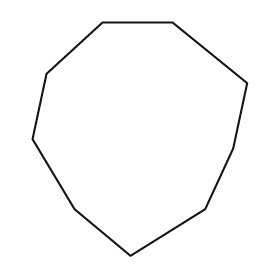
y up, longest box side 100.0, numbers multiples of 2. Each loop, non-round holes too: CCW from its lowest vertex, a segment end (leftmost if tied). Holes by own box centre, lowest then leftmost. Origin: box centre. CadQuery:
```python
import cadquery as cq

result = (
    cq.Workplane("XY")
    .moveTo(-4.0, -50.0)
    .lineTo(28.0, -30.0)
    .lineTo(40.0, -4.0)
    .lineTo(46.0, 24.0)
    .lineTo(14.0, 50.0)
    .lineTo(-16.0, 50.0)
    .lineTo(-40.0, 28.0)
    .lineTo(-46.0, 0.0)
    .lineTo(-28.0, -30.0)
    .close()
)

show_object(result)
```